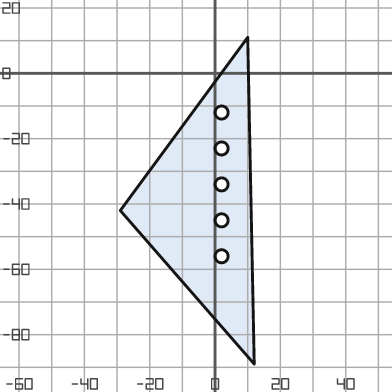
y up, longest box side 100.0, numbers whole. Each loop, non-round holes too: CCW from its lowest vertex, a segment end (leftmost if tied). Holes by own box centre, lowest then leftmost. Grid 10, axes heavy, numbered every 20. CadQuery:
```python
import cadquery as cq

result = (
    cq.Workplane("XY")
    .moveTo(12.0, -89.0)
    .lineTo(10.0, 11.0)
    .lineTo(-29.0, -42.0)
    .close()
    .moveTo(2.0, -56.0)
    .circle(2.0)
    .moveTo(2.0, -45.0)
    .circle(2.0)
    .moveTo(2.0, -34.0)
    .circle(2.0)
    .moveTo(2.0, -23.0)
    .circle(2.0)
    .moveTo(2.0, -12.0)
    .circle(2.0)
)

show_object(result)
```